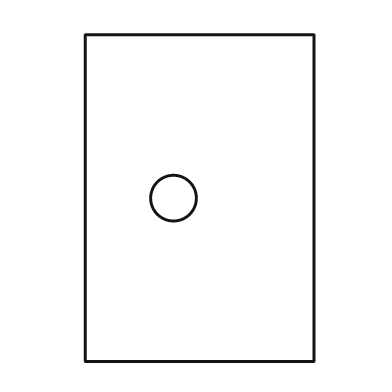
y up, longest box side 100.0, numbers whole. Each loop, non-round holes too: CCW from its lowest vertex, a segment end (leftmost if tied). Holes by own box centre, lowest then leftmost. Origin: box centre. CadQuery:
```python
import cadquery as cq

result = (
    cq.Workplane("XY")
    .moveTo(-35.0, -50.0)
    .lineTo(35.0, -50.0)
    .lineTo(35.0, 50.0)
    .lineTo(-35.0, 50.0)
    .close()
    .moveTo(-8.0, 0.0)
    .circle(7.0)
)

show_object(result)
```